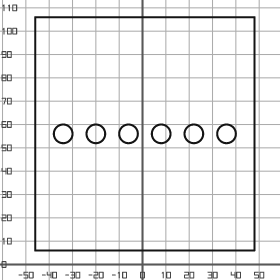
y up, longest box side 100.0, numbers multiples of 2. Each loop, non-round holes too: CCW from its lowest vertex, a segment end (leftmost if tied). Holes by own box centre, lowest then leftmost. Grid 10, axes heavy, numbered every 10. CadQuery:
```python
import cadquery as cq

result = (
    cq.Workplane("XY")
    .moveTo(-46.0, 6.0)
    .lineTo(48.0, 6.0)
    .lineTo(48.0, 106.0)
    .lineTo(-46.0, 106.0)
    .close()
    .moveTo(-34.0, 56.0)
    .circle(4.0)
    .moveTo(-20.0, 56.0)
    .circle(4.0)
    .moveTo(-6.0, 56.0)
    .circle(4.0)
    .moveTo(8.0, 56.0)
    .circle(4.0)
    .moveTo(22.0, 56.0)
    .circle(4.0)
    .moveTo(36.0, 56.0)
    .circle(4.0)
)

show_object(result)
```